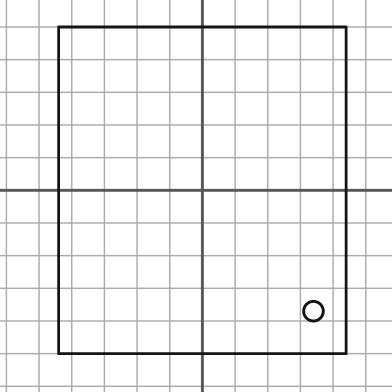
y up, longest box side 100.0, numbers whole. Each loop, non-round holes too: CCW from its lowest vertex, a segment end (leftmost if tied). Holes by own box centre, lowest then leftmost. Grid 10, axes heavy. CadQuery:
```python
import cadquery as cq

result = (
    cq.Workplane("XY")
    .moveTo(-44.0, -50.0)
    .lineTo(44.0, -50.0)
    .lineTo(44.0, 50.0)
    .lineTo(-44.0, 50.0)
    .close()
    .moveTo(34.0, -37.0)
    .circle(3.0)
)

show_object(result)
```